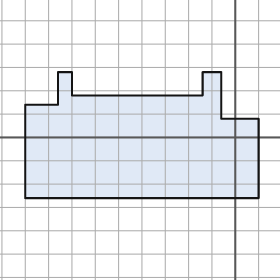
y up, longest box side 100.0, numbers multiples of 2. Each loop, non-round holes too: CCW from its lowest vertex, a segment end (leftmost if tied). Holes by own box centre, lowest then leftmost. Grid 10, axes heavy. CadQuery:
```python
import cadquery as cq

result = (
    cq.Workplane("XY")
    .moveTo(-90.0, -26.0)
    .lineTo(10.0, -26.0)
    .lineTo(10.0, 8.0)
    .lineTo(-6.0, 8.0)
    .lineTo(-6.0, 28.0)
    .lineTo(-14.0, 28.0)
    .lineTo(-14.0, 18.0)
    .lineTo(-70.0, 18.0)
    .lineTo(-70.0, 28.0)
    .lineTo(-76.0, 28.0)
    .lineTo(-76.0, 14.0)
    .lineTo(-90.0, 14.0)
    .close()
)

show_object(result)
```